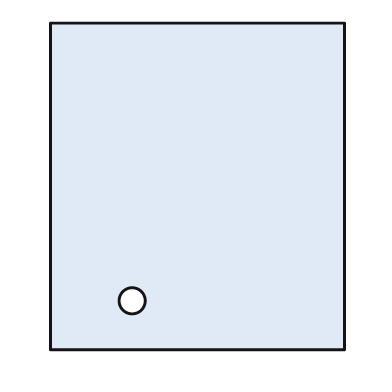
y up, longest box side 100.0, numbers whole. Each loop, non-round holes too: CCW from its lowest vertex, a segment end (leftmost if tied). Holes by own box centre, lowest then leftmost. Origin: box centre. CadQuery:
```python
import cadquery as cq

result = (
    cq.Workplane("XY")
    .moveTo(-45.0, -50.0)
    .lineTo(45.0, -50.0)
    .lineTo(45.0, 50.0)
    .lineTo(-45.0, 50.0)
    .close()
    .moveTo(-20.0, -35.0)
    .circle(4.0)
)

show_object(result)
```